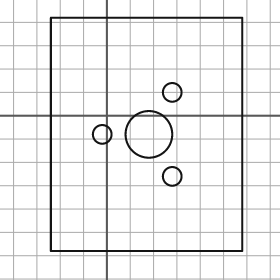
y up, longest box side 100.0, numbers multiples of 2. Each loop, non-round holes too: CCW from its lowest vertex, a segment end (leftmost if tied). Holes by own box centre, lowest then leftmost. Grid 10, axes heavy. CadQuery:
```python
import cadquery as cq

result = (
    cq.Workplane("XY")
    .moveTo(-24.0, -58.0)
    .lineTo(58.0, -58.0)
    .lineTo(58.0, 42.0)
    .lineTo(-24.0, 42.0)
    .close()
    .moveTo(28.0, -26.0)
    .circle(4.0)
    .moveTo(-2.0, -8.0)
    .circle(4.0)
    .moveTo(18.0, -8.0)
    .circle(10.0)
    .moveTo(28.0, 10.0)
    .circle(4.0)
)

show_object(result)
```